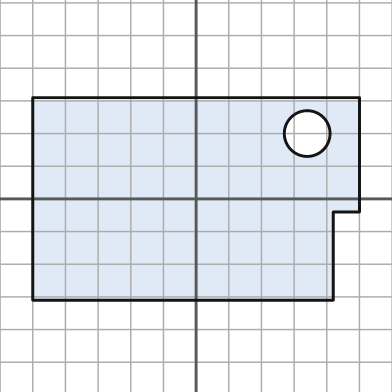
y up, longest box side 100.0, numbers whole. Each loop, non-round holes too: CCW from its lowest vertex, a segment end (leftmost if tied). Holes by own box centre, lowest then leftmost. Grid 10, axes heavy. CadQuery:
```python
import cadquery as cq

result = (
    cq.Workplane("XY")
    .moveTo(-50.0, -31.0)
    .lineTo(42.0, -31.0)
    .lineTo(42.0, -4.0)
    .lineTo(50.0, -4.0)
    .lineTo(50.0, 31.0)
    .lineTo(-50.0, 31.0)
    .close()
    .moveTo(34.0, 20.0)
    .circle(7.0)
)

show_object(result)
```